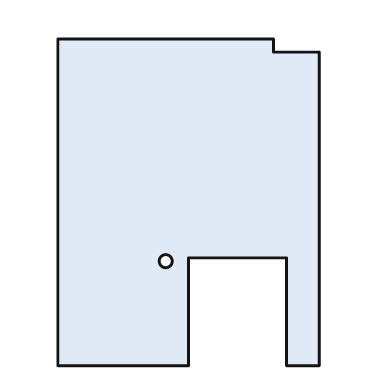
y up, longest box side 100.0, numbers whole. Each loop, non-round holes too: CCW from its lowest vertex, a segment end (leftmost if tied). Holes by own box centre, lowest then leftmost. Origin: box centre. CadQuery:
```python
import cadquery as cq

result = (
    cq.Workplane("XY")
    .moveTo(-40.0, -50.0)
    .lineTo(0.0, -50.0)
    .lineTo(0.0, -17.0)
    .lineTo(30.0, -17.0)
    .lineTo(30.0, -50.0)
    .lineTo(40.0, -50.0)
    .lineTo(40.0, 46.0)
    .lineTo(26.0, 46.0)
    .lineTo(26.0, 50.0)
    .lineTo(-40.0, 50.0)
    .close()
    .moveTo(-7.0, -18.0)
    .circle(2.0)
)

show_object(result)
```